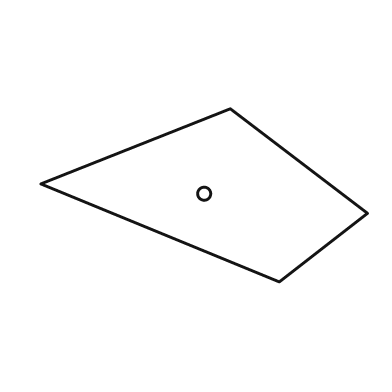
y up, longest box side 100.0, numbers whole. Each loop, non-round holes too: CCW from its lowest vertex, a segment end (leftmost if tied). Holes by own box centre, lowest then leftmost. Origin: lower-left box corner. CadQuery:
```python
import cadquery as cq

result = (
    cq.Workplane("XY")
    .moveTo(73.0, 0.0)
    .lineTo(100.0, 21.0)
    .lineTo(58.0, 53.0)
    .lineTo(0.0, 30.0)
    .close()
    .moveTo(50.0, 27.0)
    .circle(2.0)
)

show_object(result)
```